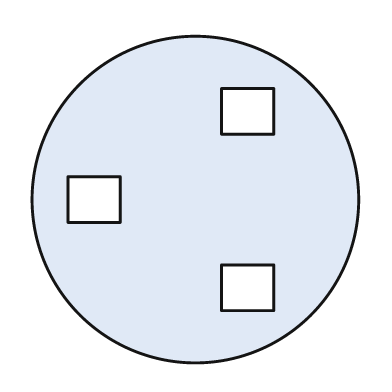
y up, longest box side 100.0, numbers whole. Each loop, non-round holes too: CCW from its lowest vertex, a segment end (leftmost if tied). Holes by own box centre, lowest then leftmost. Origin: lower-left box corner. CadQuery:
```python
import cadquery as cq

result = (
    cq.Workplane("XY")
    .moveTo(50.0, 50.0)
    .circle(50.0)
    .moveTo(58.0, 16.0)
    .lineTo(74.0, 16.0)
    .lineTo(74.0, 30.0)
    .lineTo(58.0, 30.0)
    .close()
    .moveTo(11.0, 43.0)
    .lineTo(27.0, 43.0)
    .lineTo(27.0, 57.0)
    .lineTo(11.0, 57.0)
    .close()
    .moveTo(58.0, 70.0)
    .lineTo(74.0, 70.0)
    .lineTo(74.0, 84.0)
    .lineTo(58.0, 84.0)
    .close()
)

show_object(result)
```